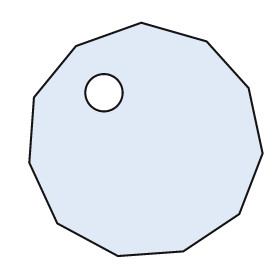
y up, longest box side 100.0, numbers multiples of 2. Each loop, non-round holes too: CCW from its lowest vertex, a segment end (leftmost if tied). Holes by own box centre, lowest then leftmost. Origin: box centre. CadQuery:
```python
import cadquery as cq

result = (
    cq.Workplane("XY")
    .moveTo(-12.0, -50.0)
    .lineTo(16.0, -48.0)
    .lineTo(40.0, -32.0)
    .lineTo(50.0, -6.0)
    .lineTo(44.0, 22.0)
    .lineTo(26.0, 42.0)
    .lineTo(-2.0, 50.0)
    .lineTo(-30.0, 40.0)
    .lineTo(-48.0, 18.0)
    .lineTo(-50.0, -10.0)
    .lineTo(-38.0, -36.0)
    .close()
    .moveTo(-18.0, 20.0)
    .circle(8.0)
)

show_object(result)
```